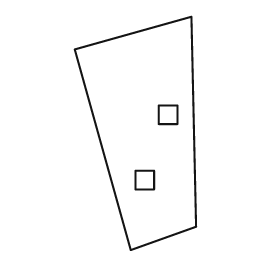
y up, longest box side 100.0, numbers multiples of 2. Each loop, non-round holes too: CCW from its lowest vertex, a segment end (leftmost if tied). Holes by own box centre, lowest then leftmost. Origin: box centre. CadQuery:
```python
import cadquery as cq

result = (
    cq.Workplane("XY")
    .moveTo(-2.0, -50.0)
    .lineTo(26.0, -40.0)
    .lineTo(24.0, 50.0)
    .lineTo(-26.0, 36.0)
    .close()
    .moveTo(0.0, -24.0)
    .lineTo(8.0, -24.0)
    .lineTo(8.0, -16.0)
    .lineTo(0.0, -16.0)
    .close()
    .moveTo(10.0, 4.0)
    .lineTo(18.0, 4.0)
    .lineTo(18.0, 12.0)
    .lineTo(10.0, 12.0)
    .close()
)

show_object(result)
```